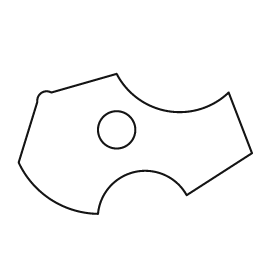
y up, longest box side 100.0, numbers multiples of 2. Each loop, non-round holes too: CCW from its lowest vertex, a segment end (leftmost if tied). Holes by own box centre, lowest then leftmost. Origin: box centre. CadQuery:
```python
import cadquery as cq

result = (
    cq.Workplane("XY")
    .moveTo(-16.0, -30.0)
    .threePointArc((0.0, -12.0), (22.0, -22.0))
    .lineTo(50.0, -4.0)
    .lineTo(40.0, 22.0)
    .threePointArc((14.0, 14.0), (-8.0, 30.0))
    .lineTo(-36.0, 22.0)
    .threePointArc((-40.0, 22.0), (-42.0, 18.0))
    .lineTo(-50.0, -8.0)
    .threePointArc((-36.0, -24.0), (-16.0, -30.0))
    .close()
    .moveTo(-8.0, 6.0)
    .circle(8.0)
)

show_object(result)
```